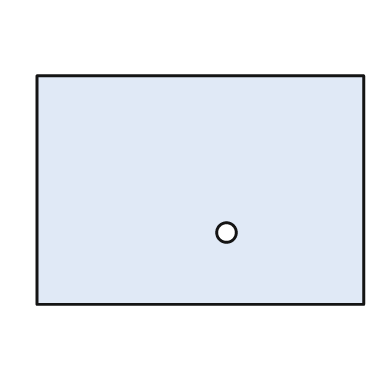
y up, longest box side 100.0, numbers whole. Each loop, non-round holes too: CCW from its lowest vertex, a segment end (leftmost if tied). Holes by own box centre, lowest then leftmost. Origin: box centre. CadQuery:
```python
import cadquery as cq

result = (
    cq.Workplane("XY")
    .moveTo(-50.0, -35.0)
    .lineTo(50.0, -35.0)
    .lineTo(50.0, 35.0)
    .lineTo(-50.0, 35.0)
    .close()
    .moveTo(8.0, -13.0)
    .circle(3.0)
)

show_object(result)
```